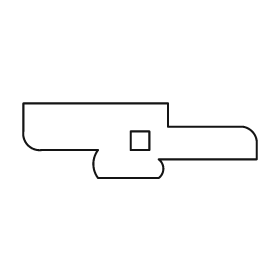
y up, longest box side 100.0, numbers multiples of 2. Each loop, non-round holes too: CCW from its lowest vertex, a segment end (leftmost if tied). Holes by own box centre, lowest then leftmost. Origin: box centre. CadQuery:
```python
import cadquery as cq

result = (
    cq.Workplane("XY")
    .moveTo(-18.0, -16.0)
    .lineTo(8.0, -16.0)
    .threePointArc((10.0, -12.0), (8.0, -8.0))
    .lineTo(50.0, -8.0)
    .lineTo(50.0, 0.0)
    .threePointArc((48.0, 4.0), (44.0, 6.0))
    .lineTo(12.0, 6.0)
    .lineTo(12.0, 16.0)
    .lineTo(-50.0, 16.0)
    .lineTo(-50.0, 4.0)
    .threePointArc((-48.0, -2.0), (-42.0, -4.0))
    .lineTo(-18.0, -4.0)
    .threePointArc((-20.0, -10.0), (-18.0, -16.0))
    .close()
    .moveTo(-4.0, -4.0)
    .lineTo(4.0, -4.0)
    .lineTo(4.0, 4.0)
    .lineTo(-4.0, 4.0)
    .close()
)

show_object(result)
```